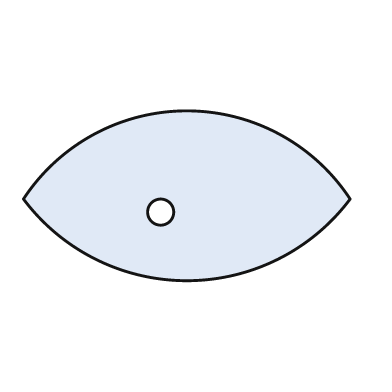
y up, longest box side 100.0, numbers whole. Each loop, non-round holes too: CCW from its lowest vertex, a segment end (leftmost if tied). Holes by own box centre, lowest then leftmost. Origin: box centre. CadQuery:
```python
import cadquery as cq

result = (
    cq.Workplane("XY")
    .moveTo(-50.0, -1.0)
    .threePointArc((0.0, -26.0), (50.0, -1.0))
    .threePointArc((0.0, 26.0), (-50.0, -1.0))
    .close()
    .moveTo(-8.0, -5.0)
    .circle(4.0)
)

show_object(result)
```